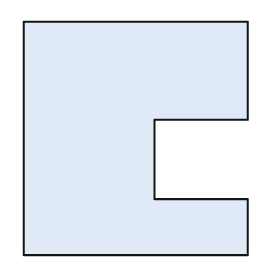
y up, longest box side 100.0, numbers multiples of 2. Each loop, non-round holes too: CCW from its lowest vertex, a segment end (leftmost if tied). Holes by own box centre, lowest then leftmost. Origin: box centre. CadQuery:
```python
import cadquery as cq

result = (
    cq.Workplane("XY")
    .moveTo(-48.0, -50.0)
    .lineTo(48.0, -50.0)
    .lineTo(48.0, -26.0)
    .lineTo(8.0, -26.0)
    .lineTo(8.0, 8.0)
    .lineTo(48.0, 8.0)
    .lineTo(48.0, 50.0)
    .lineTo(-48.0, 50.0)
    .close()
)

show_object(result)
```